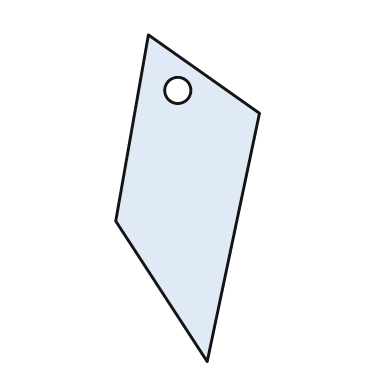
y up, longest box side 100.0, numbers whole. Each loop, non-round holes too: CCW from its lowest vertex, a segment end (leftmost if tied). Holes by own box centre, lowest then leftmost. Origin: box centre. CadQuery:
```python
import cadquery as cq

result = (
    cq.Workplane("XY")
    .moveTo(6.0, -50.0)
    .lineTo(22.0, 26.0)
    .lineTo(-12.0, 50.0)
    .lineTo(-22.0, -7.0)
    .close()
    .moveTo(-3.0, 33.0)
    .circle(4.0)
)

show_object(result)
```